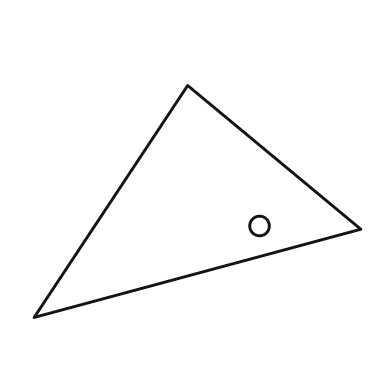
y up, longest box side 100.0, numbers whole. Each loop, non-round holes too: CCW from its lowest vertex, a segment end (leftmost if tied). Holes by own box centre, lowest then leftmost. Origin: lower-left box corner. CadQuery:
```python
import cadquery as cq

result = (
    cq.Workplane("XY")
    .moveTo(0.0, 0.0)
    .lineTo(100.0, 27.0)
    .lineTo(47.0, 71.0)
    .close()
    .moveTo(69.0, 28.0)
    .circle(3.0)
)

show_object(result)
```